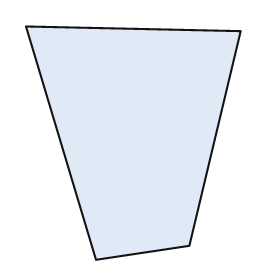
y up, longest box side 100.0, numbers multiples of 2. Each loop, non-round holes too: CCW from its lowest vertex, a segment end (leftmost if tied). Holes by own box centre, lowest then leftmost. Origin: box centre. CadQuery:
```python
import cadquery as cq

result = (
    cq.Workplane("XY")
    .moveTo(-16.0, -50.0)
    .lineTo(24.0, -44.0)
    .lineTo(46.0, 48.0)
    .lineTo(-46.0, 50.0)
    .close()
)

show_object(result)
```